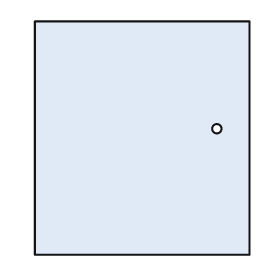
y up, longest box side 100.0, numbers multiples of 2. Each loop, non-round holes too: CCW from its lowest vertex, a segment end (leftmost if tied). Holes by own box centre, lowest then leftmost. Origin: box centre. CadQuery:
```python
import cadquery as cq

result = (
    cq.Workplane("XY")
    .moveTo(-46.0, -50.0)
    .lineTo(46.0, -50.0)
    .lineTo(46.0, 50.0)
    .lineTo(-46.0, 50.0)
    .close()
    .moveTo(32.0, 4.0)
    .circle(2.0)
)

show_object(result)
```